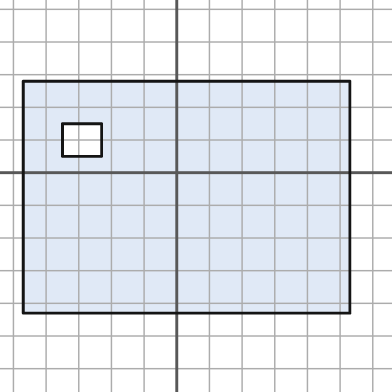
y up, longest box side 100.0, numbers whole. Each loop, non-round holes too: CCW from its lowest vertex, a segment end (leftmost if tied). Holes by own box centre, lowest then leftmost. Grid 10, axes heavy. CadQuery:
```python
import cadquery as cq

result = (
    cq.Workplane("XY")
    .moveTo(-47.0, -43.0)
    .lineTo(53.0, -43.0)
    .lineTo(53.0, 28.0)
    .lineTo(-47.0, 28.0)
    .close()
    .moveTo(-35.0, 5.0)
    .lineTo(-23.0, 5.0)
    .lineTo(-23.0, 15.0)
    .lineTo(-35.0, 15.0)
    .close()
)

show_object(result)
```